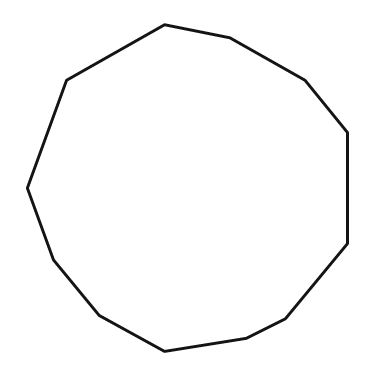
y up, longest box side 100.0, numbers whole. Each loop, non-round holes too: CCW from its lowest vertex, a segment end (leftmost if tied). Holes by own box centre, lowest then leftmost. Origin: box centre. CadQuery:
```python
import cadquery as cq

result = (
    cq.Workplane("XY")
    .moveTo(-7.0, -50.0)
    .lineTo(18.0, -46.0)
    .lineTo(30.0, -40.0)
    .lineTo(49.0, -17.0)
    .lineTo(49.0, 17.0)
    .lineTo(36.0, 33.0)
    .lineTo(13.0, 46.0)
    .lineTo(-7.0, 50.0)
    .lineTo(-37.0, 33.0)
    .lineTo(-49.0, 0.0)
    .lineTo(-41.0, -22.0)
    .lineTo(-27.0, -39.0)
    .close()
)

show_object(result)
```